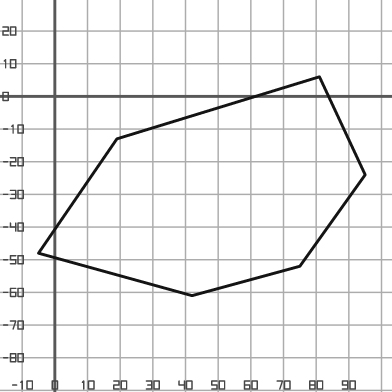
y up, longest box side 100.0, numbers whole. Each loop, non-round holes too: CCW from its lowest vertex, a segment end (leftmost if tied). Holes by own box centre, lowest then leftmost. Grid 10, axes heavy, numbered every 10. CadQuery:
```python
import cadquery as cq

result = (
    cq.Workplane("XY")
    .moveTo(42.0, -61.0)
    .lineTo(75.0, -52.0)
    .lineTo(95.0, -24.0)
    .lineTo(81.0, 6.0)
    .lineTo(19.0, -13.0)
    .lineTo(-5.0, -48.0)
    .close()
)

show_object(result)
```